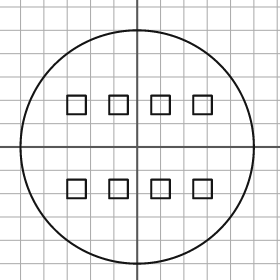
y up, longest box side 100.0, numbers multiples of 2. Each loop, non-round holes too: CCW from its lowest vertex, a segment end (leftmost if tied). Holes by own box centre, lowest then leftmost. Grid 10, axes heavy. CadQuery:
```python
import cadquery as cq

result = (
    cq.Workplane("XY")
    .moveTo(0.0, 0.0)
    .circle(50.0)
    .moveTo(-30.0, -22.0)
    .lineTo(-22.0, -22.0)
    .lineTo(-22.0, -14.0)
    .lineTo(-30.0, -14.0)
    .close()
    .moveTo(-12.0, -22.0)
    .lineTo(-4.0, -22.0)
    .lineTo(-4.0, -14.0)
    .lineTo(-12.0, -14.0)
    .close()
    .moveTo(6.0, -22.0)
    .lineTo(14.0, -22.0)
    .lineTo(14.0, -14.0)
    .lineTo(6.0, -14.0)
    .close()
    .moveTo(24.0, -22.0)
    .lineTo(32.0, -22.0)
    .lineTo(32.0, -14.0)
    .lineTo(24.0, -14.0)
    .close()
    .moveTo(-30.0, 14.0)
    .lineTo(-22.0, 14.0)
    .lineTo(-22.0, 22.0)
    .lineTo(-30.0, 22.0)
    .close()
    .moveTo(-12.0, 14.0)
    .lineTo(-4.0, 14.0)
    .lineTo(-4.0, 22.0)
    .lineTo(-12.0, 22.0)
    .close()
    .moveTo(6.0, 14.0)
    .lineTo(14.0, 14.0)
    .lineTo(14.0, 22.0)
    .lineTo(6.0, 22.0)
    .close()
    .moveTo(24.0, 14.0)
    .lineTo(32.0, 14.0)
    .lineTo(32.0, 22.0)
    .lineTo(24.0, 22.0)
    .close()
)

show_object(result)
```